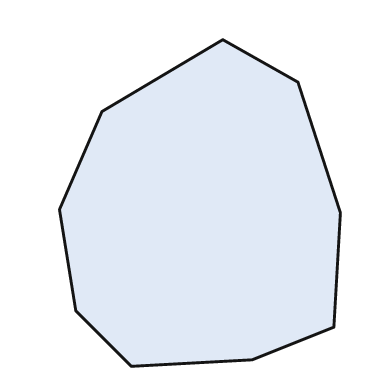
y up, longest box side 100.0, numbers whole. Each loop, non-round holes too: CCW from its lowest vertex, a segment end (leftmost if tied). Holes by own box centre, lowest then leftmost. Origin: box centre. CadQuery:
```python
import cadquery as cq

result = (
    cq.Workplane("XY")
    .moveTo(-21.0, -50.0)
    .lineTo(16.0, -48.0)
    .lineTo(41.0, -38.0)
    .lineTo(43.0, -3.0)
    .lineTo(30.0, 37.0)
    .lineTo(7.0, 50.0)
    .lineTo(-30.0, 28.0)
    .lineTo(-43.0, -2.0)
    .lineTo(-38.0, -33.0)
    .close()
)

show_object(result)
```